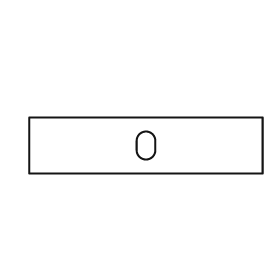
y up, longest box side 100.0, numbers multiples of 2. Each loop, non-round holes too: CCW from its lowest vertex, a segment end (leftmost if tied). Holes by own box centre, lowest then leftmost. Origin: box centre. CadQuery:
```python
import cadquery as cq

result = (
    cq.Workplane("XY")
    .moveTo(-50.0, -12.0)
    .lineTo(50.0, -12.0)
    .lineTo(50.0, 12.0)
    .lineTo(-50.0, 12.0)
    .close()
    .moveTo(-4.0, -2.0)
    .threePointArc((0.0, -6.0), (4.0, -2.0))
    .lineTo(4.0, 2.0)
    .threePointArc((0.0, 6.0), (-4.0, 2.0))
    .close()
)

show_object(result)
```